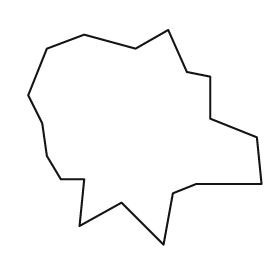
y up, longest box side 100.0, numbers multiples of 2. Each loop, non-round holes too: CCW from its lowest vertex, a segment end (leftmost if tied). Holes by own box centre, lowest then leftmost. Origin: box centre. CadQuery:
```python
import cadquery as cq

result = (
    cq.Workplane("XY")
    .moveTo(8.0, -46.0)
    .lineTo(12.0, -24.0)
    .lineTo(22.0, -20.0)
    .lineTo(50.0, -20.0)
    .lineTo(48.0, 0.0)
    .lineTo(28.0, 8.0)
    .lineTo(28.0, 26.0)
    .lineTo(18.0, 28.0)
    .lineTo(10.0, 46.0)
    .lineTo(-4.0, 38.0)
    .lineTo(-26.0, 44.0)
    .lineTo(-42.0, 38.0)
    .lineTo(-50.0, 18.0)
    .lineTo(-44.0, 6.0)
    .lineTo(-42.0, -8.0)
    .lineTo(-36.0, -18.0)
    .lineTo(-26.0, -18.0)
    .lineTo(-28.0, -38.0)
    .lineTo(-10.0, -28.0)
    .close()
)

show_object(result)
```